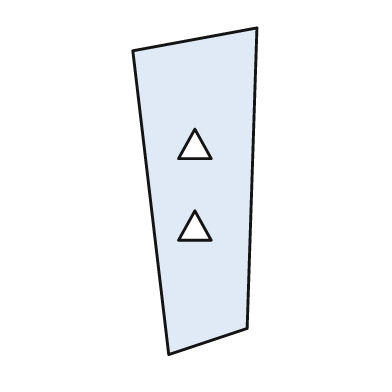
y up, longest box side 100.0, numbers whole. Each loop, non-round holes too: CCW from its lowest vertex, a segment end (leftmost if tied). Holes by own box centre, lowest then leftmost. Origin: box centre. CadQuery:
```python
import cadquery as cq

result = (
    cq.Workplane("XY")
    .moveTo(-8.0, -50.0)
    .lineTo(16.0, -42.0)
    .lineTo(19.0, 50.0)
    .lineTo(-19.0, 43.0)
    .close()
    .moveTo(-5.0, -15.0)
    .lineTo(5.0, -15.0)
    .lineTo(0.0, -6.0)
    .close()
    .moveTo(-5.0, 10.0)
    .lineTo(5.0, 10.0)
    .lineTo(0.0, 19.0)
    .close()
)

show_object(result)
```